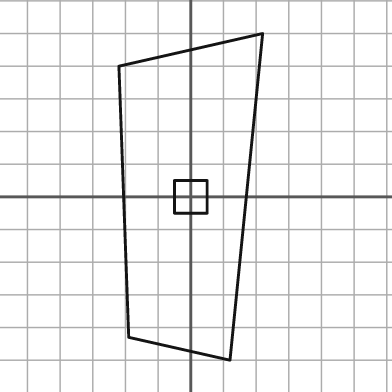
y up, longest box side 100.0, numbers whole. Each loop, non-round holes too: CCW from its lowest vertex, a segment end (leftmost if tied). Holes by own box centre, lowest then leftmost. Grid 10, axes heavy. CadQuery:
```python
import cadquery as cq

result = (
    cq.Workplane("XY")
    .moveTo(12.0, -50.0)
    .lineTo(22.0, 50.0)
    .lineTo(-22.0, 40.0)
    .lineTo(-19.0, -43.0)
    .close()
    .moveTo(-5.0, -5.0)
    .lineTo(5.0, -5.0)
    .lineTo(5.0, 5.0)
    .lineTo(-5.0, 5.0)
    .close()
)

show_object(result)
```